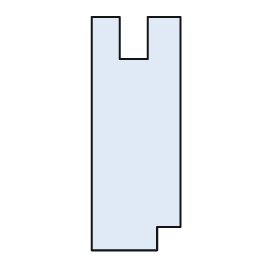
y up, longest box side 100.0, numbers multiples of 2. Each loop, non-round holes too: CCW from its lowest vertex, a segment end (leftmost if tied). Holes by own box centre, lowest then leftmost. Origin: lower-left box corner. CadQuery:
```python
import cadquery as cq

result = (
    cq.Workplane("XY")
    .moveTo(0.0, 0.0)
    .lineTo(28.0, 0.0)
    .lineTo(28.0, 10.0)
    .lineTo(38.0, 10.0)
    .lineTo(38.0, 100.0)
    .lineTo(24.0, 100.0)
    .lineTo(24.0, 82.0)
    .lineTo(12.0, 82.0)
    .lineTo(12.0, 100.0)
    .lineTo(0.0, 100.0)
    .close()
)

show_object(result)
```